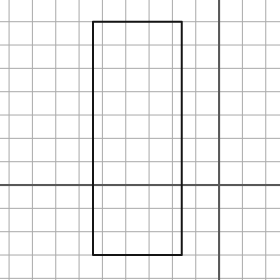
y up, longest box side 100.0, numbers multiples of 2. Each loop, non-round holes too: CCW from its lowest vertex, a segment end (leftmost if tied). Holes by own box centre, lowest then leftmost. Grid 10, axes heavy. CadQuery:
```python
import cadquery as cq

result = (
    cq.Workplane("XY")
    .moveTo(-54.0, -30.0)
    .lineTo(-16.0, -30.0)
    .lineTo(-16.0, 70.0)
    .lineTo(-54.0, 70.0)
    .close()
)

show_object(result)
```